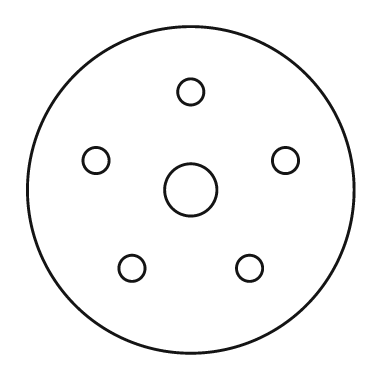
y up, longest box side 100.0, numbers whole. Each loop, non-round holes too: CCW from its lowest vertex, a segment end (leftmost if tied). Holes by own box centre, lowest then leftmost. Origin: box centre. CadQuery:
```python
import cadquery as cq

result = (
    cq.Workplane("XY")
    .moveTo(0.0, 0.0)
    .circle(50.0)
    .moveTo(-18.0, -24.0)
    .circle(4.0)
    .moveTo(18.0, -24.0)
    .circle(4.0)
    .moveTo(0.0, 0.0)
    .circle(8.0)
    .moveTo(-29.0, 9.0)
    .circle(4.0)
    .moveTo(29.0, 9.0)
    .circle(4.0)
    .moveTo(0.0, 30.0)
    .circle(4.0)
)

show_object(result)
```